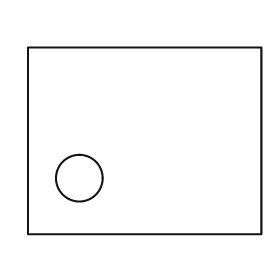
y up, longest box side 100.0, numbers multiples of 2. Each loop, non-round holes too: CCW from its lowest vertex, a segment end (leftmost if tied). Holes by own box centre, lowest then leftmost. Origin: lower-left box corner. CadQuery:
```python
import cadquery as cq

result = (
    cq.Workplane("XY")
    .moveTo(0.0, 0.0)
    .lineTo(100.0, 0.0)
    .lineTo(100.0, 80.0)
    .lineTo(0.0, 80.0)
    .close()
    .moveTo(22.0, 24.0)
    .circle(10.0)
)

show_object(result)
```